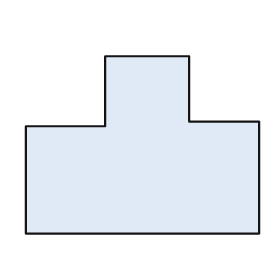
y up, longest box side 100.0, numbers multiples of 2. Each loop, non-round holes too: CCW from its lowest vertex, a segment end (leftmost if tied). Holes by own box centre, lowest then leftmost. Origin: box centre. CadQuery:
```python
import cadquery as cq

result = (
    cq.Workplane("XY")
    .moveTo(-50.0, -38.0)
    .lineTo(50.0, -38.0)
    .lineTo(50.0, 10.0)
    .lineTo(20.0, 10.0)
    .lineTo(20.0, 38.0)
    .lineTo(-16.0, 38.0)
    .lineTo(-16.0, 8.0)
    .lineTo(-50.0, 8.0)
    .close()
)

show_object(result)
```